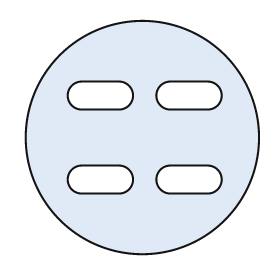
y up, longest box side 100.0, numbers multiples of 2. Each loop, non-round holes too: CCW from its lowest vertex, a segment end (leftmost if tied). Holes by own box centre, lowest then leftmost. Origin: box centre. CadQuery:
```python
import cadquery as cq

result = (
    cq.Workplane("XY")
    .moveTo(0.0, 0.0)
    .circle(50.0)
    .moveTo(-26.0, -24.0)
    .lineTo(-10.0, -24.0)
    .threePointArc((-4.0, -18.0), (-10.0, -12.0))
    .lineTo(-26.0, -12.0)
    .threePointArc((-32.0, -18.0), (-26.0, -24.0))
    .close()
    .moveTo(12.0, -24.0)
    .lineTo(28.0, -24.0)
    .threePointArc((34.0, -18.0), (28.0, -12.0))
    .lineTo(12.0, -12.0)
    .threePointArc((6.0, -18.0), (12.0, -24.0))
    .close()
    .moveTo(-26.0, 12.0)
    .lineTo(-10.0, 12.0)
    .threePointArc((-4.0, 18.0), (-10.0, 24.0))
    .lineTo(-26.0, 24.0)
    .threePointArc((-32.0, 18.0), (-26.0, 12.0))
    .close()
    .moveTo(12.0, 12.0)
    .lineTo(28.0, 12.0)
    .threePointArc((34.0, 18.0), (28.0, 24.0))
    .lineTo(12.0, 24.0)
    .threePointArc((6.0, 18.0), (12.0, 12.0))
    .close()
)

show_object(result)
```